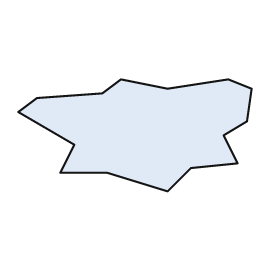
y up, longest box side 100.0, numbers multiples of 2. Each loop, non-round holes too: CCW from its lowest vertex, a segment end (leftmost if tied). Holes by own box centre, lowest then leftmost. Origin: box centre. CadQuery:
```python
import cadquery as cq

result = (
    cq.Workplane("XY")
    .moveTo(14.0, -24.0)
    .lineTo(24.0, -14.0)
    .lineTo(44.0, -12.0)
    .lineTo(38.0, 0.0)
    .lineTo(48.0, 6.0)
    .lineTo(50.0, 20.0)
    .lineTo(40.0, 24.0)
    .lineTo(14.0, 20.0)
    .lineTo(-6.0, 24.0)
    .lineTo(-14.0, 18.0)
    .lineTo(-42.0, 16.0)
    .lineTo(-50.0, 10.0)
    .lineTo(-26.0, -4.0)
    .lineTo(-32.0, -16.0)
    .lineTo(-12.0, -16.0)
    .close()
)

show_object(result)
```